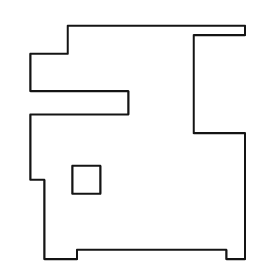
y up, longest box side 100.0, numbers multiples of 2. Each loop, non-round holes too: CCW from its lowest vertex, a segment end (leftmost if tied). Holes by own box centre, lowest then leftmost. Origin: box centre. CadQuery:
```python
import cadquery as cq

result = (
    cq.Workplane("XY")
    .moveTo(-40.0, -50.0)
    .lineTo(-26.0, -50.0)
    .lineTo(-26.0, -46.0)
    .lineTo(38.0, -46.0)
    .lineTo(38.0, -50.0)
    .lineTo(46.0, -50.0)
    .lineTo(46.0, 4.0)
    .lineTo(24.0, 4.0)
    .lineTo(24.0, 46.0)
    .lineTo(46.0, 46.0)
    .lineTo(46.0, 50.0)
    .lineTo(-30.0, 50.0)
    .lineTo(-30.0, 38.0)
    .lineTo(-46.0, 38.0)
    .lineTo(-46.0, 22.0)
    .lineTo(-4.0, 22.0)
    .lineTo(-4.0, 12.0)
    .lineTo(-46.0, 12.0)
    .lineTo(-46.0, -16.0)
    .lineTo(-40.0, -16.0)
    .close()
    .moveTo(-28.0, -22.0)
    .lineTo(-16.0, -22.0)
    .lineTo(-16.0, -10.0)
    .lineTo(-28.0, -10.0)
    .close()
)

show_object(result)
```